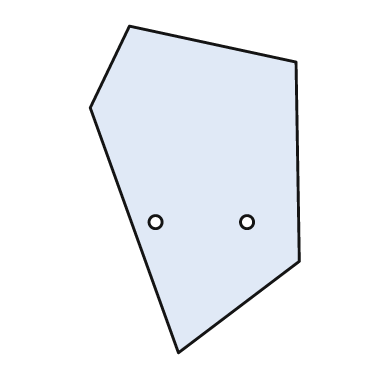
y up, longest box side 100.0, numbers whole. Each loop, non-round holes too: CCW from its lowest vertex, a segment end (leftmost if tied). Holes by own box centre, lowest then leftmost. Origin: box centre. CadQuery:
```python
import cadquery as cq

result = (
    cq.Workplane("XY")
    .moveTo(-5.0, -50.0)
    .lineTo(32.0, -22.0)
    .lineTo(31.0, 39.0)
    .lineTo(-20.0, 50.0)
    .lineTo(-32.0, 25.0)
    .close()
    .moveTo(-12.0, -10.0)
    .circle(2.0)
    .moveTo(16.0, -10.0)
    .circle(2.0)
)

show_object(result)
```